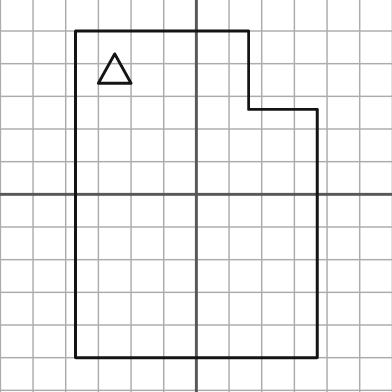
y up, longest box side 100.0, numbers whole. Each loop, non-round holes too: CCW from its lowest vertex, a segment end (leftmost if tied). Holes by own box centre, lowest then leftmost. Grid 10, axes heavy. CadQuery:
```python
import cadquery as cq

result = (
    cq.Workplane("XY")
    .moveTo(-37.0, -50.0)
    .lineTo(37.0, -50.0)
    .lineTo(37.0, 26.0)
    .lineTo(16.0, 26.0)
    .lineTo(16.0, 50.0)
    .lineTo(-37.0, 50.0)
    .close()
    .moveTo(-30.0, 34.0)
    .lineTo(-20.0, 34.0)
    .lineTo(-25.0, 43.0)
    .close()
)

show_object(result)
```